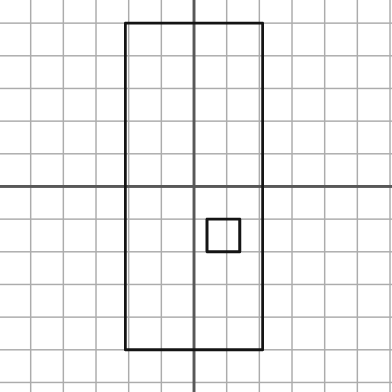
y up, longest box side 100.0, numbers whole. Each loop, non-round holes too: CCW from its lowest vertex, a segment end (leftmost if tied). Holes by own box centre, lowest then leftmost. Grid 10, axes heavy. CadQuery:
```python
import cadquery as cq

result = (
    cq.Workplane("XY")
    .moveTo(-21.0, -50.0)
    .lineTo(21.0, -50.0)
    .lineTo(21.0, 50.0)
    .lineTo(-21.0, 50.0)
    .close()
    .moveTo(4.0, -20.0)
    .lineTo(14.0, -20.0)
    .lineTo(14.0, -10.0)
    .lineTo(4.0, -10.0)
    .close()
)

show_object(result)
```